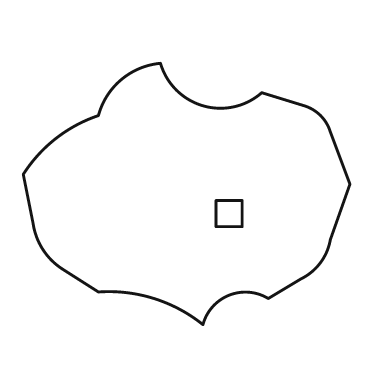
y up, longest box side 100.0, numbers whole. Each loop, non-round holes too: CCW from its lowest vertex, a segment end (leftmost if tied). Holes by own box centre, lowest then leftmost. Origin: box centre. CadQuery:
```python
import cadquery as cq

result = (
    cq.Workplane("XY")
    .moveTo(5.0, -40.0)
    .threePointArc((13.0, -31.0), (25.0, -32.0))
    .lineTo(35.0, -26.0)
    .threePointArc((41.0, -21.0), (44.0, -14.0))
    .lineTo(50.0, 3.0)
    .lineTo(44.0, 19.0)
    .threePointArc((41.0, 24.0), (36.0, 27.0))
    .lineTo(23.0, 31.0)
    .threePointArc((5.0, 27.0), (-8.0, 40.0))
    .threePointArc((-20.0, 35.0), (-27.0, 24.0))
    .threePointArc((-40.0, 17.0), (-50.0, 6.0))
    .lineTo(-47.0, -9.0)
    .threePointArc((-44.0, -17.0), (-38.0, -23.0))
    .lineTo(-27.0, -30.0)
    .threePointArc((-10.0, -32.0), (5.0, -40.0))
    .close()
    .moveTo(9.0, -10.0)
    .lineTo(17.0, -10.0)
    .lineTo(17.0, -2.0)
    .lineTo(9.0, -2.0)
    .close()
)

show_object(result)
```